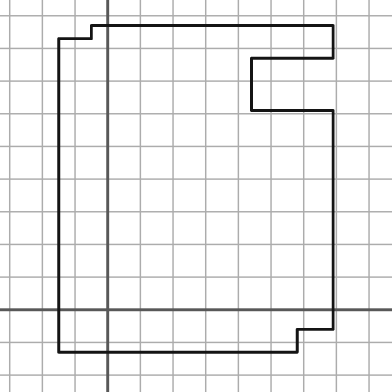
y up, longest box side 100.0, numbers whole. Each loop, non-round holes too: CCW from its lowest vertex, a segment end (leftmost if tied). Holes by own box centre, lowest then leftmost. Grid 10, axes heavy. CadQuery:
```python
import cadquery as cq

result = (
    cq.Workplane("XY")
    .moveTo(-15.0, -13.0)
    .lineTo(58.0, -13.0)
    .lineTo(58.0, -6.0)
    .lineTo(69.0, -6.0)
    .lineTo(69.0, 61.0)
    .lineTo(44.0, 61.0)
    .lineTo(44.0, 77.0)
    .lineTo(69.0, 77.0)
    .lineTo(69.0, 87.0)
    .lineTo(-5.0, 87.0)
    .lineTo(-5.0, 83.0)
    .lineTo(-15.0, 83.0)
    .close()
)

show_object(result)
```